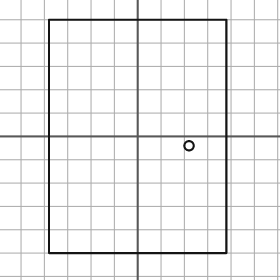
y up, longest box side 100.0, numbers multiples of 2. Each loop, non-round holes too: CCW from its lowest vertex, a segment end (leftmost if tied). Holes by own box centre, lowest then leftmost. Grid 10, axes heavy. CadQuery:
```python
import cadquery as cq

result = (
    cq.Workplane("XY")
    .moveTo(-38.0, -50.0)
    .lineTo(38.0, -50.0)
    .lineTo(38.0, 50.0)
    .lineTo(-38.0, 50.0)
    .close()
    .moveTo(22.0, -4.0)
    .circle(2.0)
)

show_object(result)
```